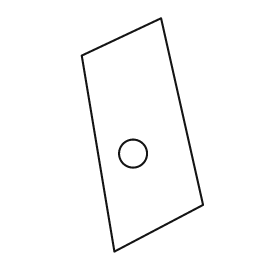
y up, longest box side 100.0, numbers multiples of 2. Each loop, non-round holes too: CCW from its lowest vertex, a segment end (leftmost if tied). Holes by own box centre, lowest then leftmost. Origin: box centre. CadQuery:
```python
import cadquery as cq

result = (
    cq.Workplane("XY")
    .moveTo(-12.0, -50.0)
    .lineTo(26.0, -30.0)
    .lineTo(8.0, 50.0)
    .lineTo(-26.0, 34.0)
    .close()
    .moveTo(-4.0, -8.0)
    .circle(6.0)
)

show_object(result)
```